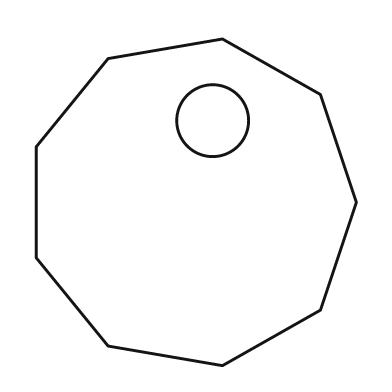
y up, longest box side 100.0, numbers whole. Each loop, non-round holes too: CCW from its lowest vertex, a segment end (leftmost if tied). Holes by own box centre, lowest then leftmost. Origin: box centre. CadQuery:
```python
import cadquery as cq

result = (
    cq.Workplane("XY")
    .moveTo(8.0, -50.0)
    .lineTo(38.0, -33.0)
    .lineTo(49.0, 0.0)
    .lineTo(38.0, 33.0)
    .lineTo(8.0, 50.0)
    .lineTo(-27.0, 44.0)
    .lineTo(-49.0, 17.0)
    .lineTo(-49.0, -17.0)
    .lineTo(-27.0, -44.0)
    .close()
    .moveTo(5.0, 25.0)
    .circle(11.0)
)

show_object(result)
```